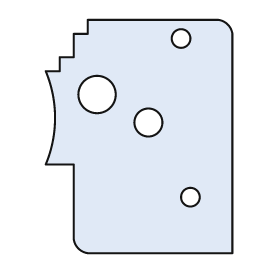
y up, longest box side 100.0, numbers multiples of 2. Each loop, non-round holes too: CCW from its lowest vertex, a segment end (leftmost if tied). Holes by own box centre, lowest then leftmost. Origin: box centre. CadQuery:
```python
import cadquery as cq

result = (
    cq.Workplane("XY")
    .moveTo(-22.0, -50.0)
    .lineTo(40.0, -50.0)
    .lineTo(40.0, 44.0)
    .threePointArc((38.0, 48.0), (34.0, 50.0))
    .lineTo(-22.0, 50.0)
    .lineTo(-22.0, 44.0)
    .lineTo(-28.0, 44.0)
    .lineTo(-28.0, 34.0)
    .lineTo(-34.0, 34.0)
    .lineTo(-34.0, 28.0)
    .lineTo(-40.0, 28.0)
    .threePointArc((-36.0, 8.0), (-40.0, -12.0))
    .lineTo(-28.0, -12.0)
    .lineTo(-28.0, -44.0)
    .threePointArc((-26.0, -48.0), (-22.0, -50.0))
    .close()
    .moveTo(22.0, -26.0)
    .circle(4.0)
    .moveTo(4.0, 6.0)
    .circle(6.0)
    .moveTo(-18.0, 18.0)
    .circle(8.0)
    .moveTo(18.0, 42.0)
    .circle(4.0)
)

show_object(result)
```